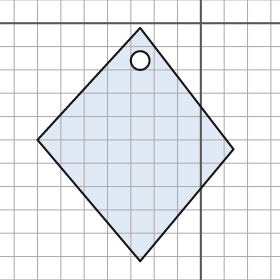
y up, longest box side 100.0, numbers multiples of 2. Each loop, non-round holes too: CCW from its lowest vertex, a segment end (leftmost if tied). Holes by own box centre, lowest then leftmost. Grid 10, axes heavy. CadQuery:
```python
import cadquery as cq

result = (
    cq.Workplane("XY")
    .moveTo(-26.0, -102.0)
    .lineTo(14.0, -54.0)
    .lineTo(-26.0, -2.0)
    .lineTo(-70.0, -50.0)
    .close()
    .moveTo(-26.0, -16.0)
    .circle(4.0)
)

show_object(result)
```